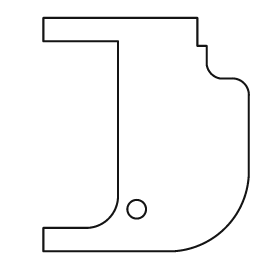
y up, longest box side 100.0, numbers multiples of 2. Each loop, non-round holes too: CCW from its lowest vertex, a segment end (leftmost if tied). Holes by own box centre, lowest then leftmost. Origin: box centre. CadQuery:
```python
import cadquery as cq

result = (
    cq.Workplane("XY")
    .moveTo(-44.0, -50.0)
    .lineTo(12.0, -50.0)
    .threePointArc((34.0, -40.0), (44.0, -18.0))
    .lineTo(44.0, 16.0)
    .threePointArc((42.0, 22.0), (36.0, 24.0))
    .lineTo(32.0, 24.0)
    .threePointArc((28.0, 26.0), (26.0, 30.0))
    .lineTo(26.0, 38.0)
    .lineTo(22.0, 38.0)
    .lineTo(22.0, 50.0)
    .lineTo(-44.0, 50.0)
    .lineTo(-44.0, 40.0)
    .lineTo(-12.0, 40.0)
    .lineTo(-12.0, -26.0)
    .threePointArc((-16.0, -36.0), (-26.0, -40.0))
    .lineTo(-44.0, -40.0)
    .close()
    .moveTo(-4.0, -32.0)
    .circle(4.0)
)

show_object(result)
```